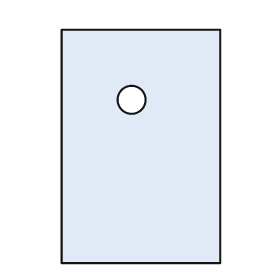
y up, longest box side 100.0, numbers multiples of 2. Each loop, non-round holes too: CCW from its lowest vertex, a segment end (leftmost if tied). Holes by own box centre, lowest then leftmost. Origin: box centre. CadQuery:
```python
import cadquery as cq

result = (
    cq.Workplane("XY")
    .moveTo(-34.0, -50.0)
    .lineTo(34.0, -50.0)
    .lineTo(34.0, 50.0)
    .lineTo(-34.0, 50.0)
    .close()
    .moveTo(-4.0, 20.0)
    .circle(6.0)
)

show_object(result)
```